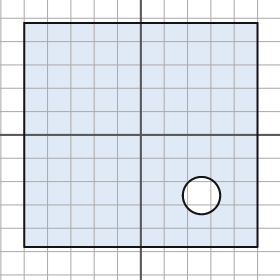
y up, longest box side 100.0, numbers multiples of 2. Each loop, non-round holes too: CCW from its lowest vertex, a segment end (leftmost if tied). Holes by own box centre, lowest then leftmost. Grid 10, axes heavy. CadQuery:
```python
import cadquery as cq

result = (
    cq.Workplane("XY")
    .moveTo(-50.0, -48.0)
    .lineTo(50.0, -48.0)
    .lineTo(50.0, 48.0)
    .lineTo(-50.0, 48.0)
    .close()
    .moveTo(26.0, -26.0)
    .circle(8.0)
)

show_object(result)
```